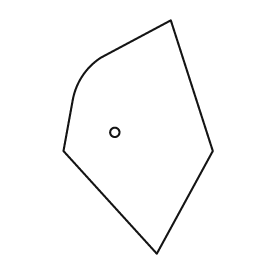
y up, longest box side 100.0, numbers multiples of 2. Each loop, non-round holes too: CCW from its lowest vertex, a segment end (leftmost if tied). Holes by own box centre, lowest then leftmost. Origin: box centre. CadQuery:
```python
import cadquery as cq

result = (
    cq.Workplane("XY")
    .moveTo(8.0, -50.0)
    .lineTo(32.0, -6.0)
    .lineTo(14.0, 50.0)
    .lineTo(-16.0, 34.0)
    .threePointArc((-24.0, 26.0), (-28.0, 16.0))
    .lineTo(-32.0, -6.0)
    .close()
    .moveTo(-10.0, 2.0)
    .circle(2.0)
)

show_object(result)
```